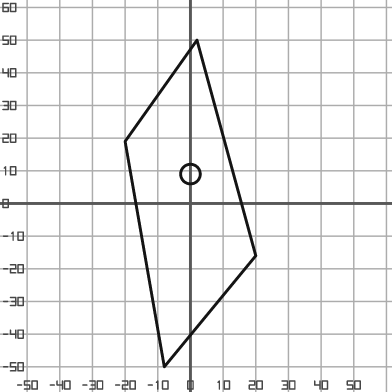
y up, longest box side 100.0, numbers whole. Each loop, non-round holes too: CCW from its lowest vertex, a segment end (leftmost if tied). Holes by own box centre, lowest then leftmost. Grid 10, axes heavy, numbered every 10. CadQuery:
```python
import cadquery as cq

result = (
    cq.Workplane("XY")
    .moveTo(-8.0, -50.0)
    .lineTo(20.0, -16.0)
    .lineTo(2.0, 50.0)
    .lineTo(-20.0, 19.0)
    .close()
    .moveTo(0.0, 9.0)
    .circle(3.0)
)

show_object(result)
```